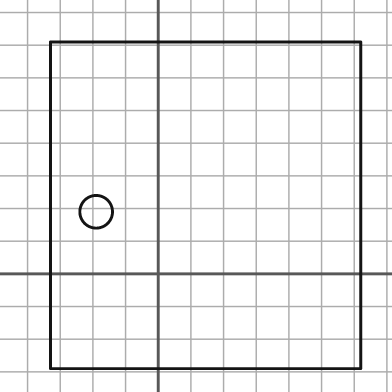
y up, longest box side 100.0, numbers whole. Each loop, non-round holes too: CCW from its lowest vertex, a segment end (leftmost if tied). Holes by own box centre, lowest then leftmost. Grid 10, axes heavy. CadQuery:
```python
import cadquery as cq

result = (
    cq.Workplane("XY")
    .moveTo(-33.0, -29.0)
    .lineTo(62.0, -29.0)
    .lineTo(62.0, 71.0)
    .lineTo(-33.0, 71.0)
    .close()
    .moveTo(-19.0, 19.0)
    .circle(5.0)
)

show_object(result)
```